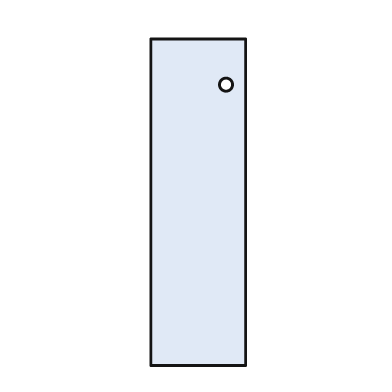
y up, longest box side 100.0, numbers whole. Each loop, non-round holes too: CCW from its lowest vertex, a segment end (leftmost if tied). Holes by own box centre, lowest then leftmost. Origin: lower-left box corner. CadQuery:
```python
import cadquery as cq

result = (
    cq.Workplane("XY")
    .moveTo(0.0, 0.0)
    .lineTo(29.0, 0.0)
    .lineTo(29.0, 100.0)
    .lineTo(0.0, 100.0)
    .close()
    .moveTo(23.0, 86.0)
    .circle(2.0)
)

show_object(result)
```